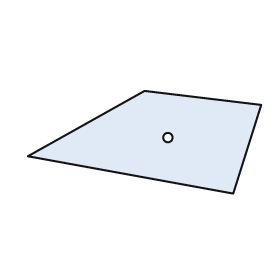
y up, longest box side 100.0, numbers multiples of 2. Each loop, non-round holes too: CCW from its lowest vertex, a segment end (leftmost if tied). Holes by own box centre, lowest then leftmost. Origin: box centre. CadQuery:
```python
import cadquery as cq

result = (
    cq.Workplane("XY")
    .moveTo(38.0, -22.0)
    .lineTo(50.0, 16.0)
    .lineTo(0.0, 22.0)
    .lineTo(-50.0, -6.0)
    .close()
    .moveTo(10.0, 2.0)
    .circle(2.0)
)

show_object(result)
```